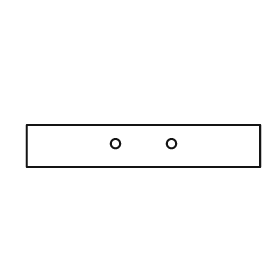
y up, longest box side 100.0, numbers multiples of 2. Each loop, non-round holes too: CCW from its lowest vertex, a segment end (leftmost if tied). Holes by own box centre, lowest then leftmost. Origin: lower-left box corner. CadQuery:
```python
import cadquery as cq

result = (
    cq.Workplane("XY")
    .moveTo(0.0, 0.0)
    .lineTo(100.0, 0.0)
    .lineTo(100.0, 18.0)
    .lineTo(0.0, 18.0)
    .close()
    .moveTo(38.0, 10.0)
    .circle(2.0)
    .moveTo(62.0, 10.0)
    .circle(2.0)
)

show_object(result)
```